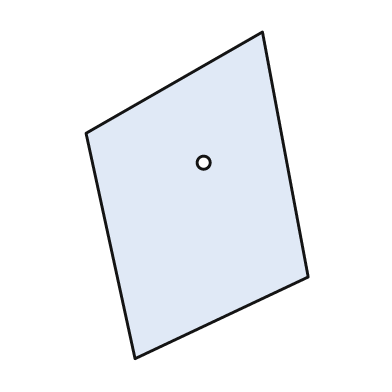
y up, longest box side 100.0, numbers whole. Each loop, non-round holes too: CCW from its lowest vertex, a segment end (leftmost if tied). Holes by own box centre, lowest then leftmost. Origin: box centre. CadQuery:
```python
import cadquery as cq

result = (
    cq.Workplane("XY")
    .moveTo(-19.0, -50.0)
    .lineTo(34.0, -25.0)
    .lineTo(20.0, 50.0)
    .lineTo(-34.0, 19.0)
    .close()
    .moveTo(2.0, 10.0)
    .circle(2.0)
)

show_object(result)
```